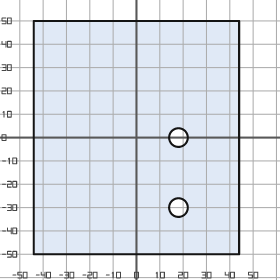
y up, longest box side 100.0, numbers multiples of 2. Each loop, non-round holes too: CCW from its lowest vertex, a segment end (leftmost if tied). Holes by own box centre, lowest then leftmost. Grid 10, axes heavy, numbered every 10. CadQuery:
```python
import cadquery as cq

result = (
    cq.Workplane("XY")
    .moveTo(-44.0, -50.0)
    .lineTo(44.0, -50.0)
    .lineTo(44.0, 50.0)
    .lineTo(-44.0, 50.0)
    .close()
    .moveTo(18.0, -30.0)
    .circle(4.0)
    .moveTo(18.0, 0.0)
    .circle(4.0)
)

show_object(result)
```